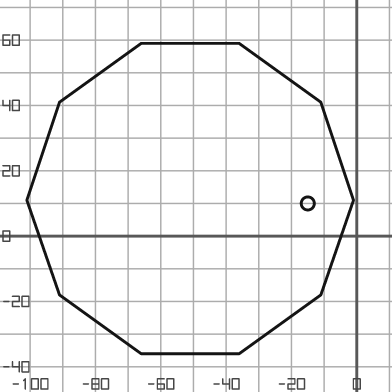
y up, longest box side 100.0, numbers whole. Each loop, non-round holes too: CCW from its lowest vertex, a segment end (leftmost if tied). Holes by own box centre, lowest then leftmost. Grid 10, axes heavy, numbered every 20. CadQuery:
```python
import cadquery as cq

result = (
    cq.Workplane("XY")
    .moveTo(-66.0, -36.0)
    .lineTo(-36.0, -36.0)
    .lineTo(-11.0, -18.0)
    .lineTo(-1.0, 11.0)
    .lineTo(-11.0, 41.0)
    .lineTo(-36.0, 59.0)
    .lineTo(-66.0, 59.0)
    .lineTo(-91.0, 41.0)
    .lineTo(-101.0, 11.0)
    .lineTo(-91.0, -18.0)
    .close()
    .moveTo(-15.0, 10.0)
    .circle(2.0)
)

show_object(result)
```